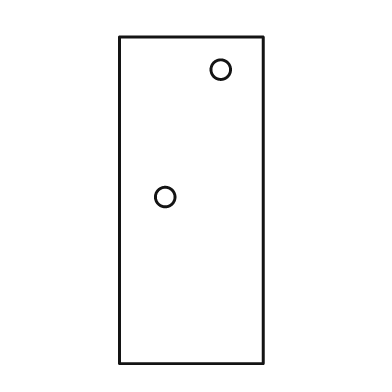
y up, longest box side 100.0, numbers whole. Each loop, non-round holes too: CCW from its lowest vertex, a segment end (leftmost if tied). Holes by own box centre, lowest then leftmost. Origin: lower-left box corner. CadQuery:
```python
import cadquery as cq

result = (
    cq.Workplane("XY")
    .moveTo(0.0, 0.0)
    .lineTo(44.0, 0.0)
    .lineTo(44.0, 100.0)
    .lineTo(0.0, 100.0)
    .close()
    .moveTo(14.0, 51.0)
    .circle(3.0)
    .moveTo(31.0, 90.0)
    .circle(3.0)
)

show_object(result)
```